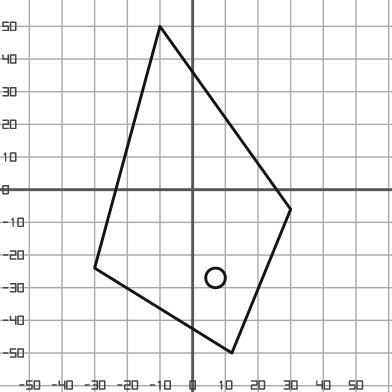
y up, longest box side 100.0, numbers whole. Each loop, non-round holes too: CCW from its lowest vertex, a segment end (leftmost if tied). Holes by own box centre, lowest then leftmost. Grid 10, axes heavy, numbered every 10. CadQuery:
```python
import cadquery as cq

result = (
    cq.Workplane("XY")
    .moveTo(12.0, -50.0)
    .lineTo(30.0, -6.0)
    .lineTo(-10.0, 50.0)
    .lineTo(-30.0, -24.0)
    .close()
    .moveTo(7.0, -27.0)
    .circle(3.0)
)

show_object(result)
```